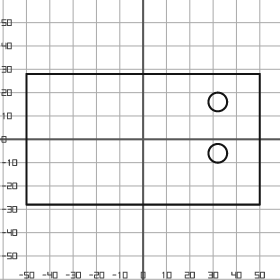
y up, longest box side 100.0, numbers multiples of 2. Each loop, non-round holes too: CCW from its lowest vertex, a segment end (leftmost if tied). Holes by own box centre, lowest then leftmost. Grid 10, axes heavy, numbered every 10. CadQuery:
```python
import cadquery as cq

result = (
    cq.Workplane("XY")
    .moveTo(-50.0, -28.0)
    .lineTo(50.0, -28.0)
    .lineTo(50.0, 28.0)
    .lineTo(-50.0, 28.0)
    .close()
    .moveTo(32.0, -6.0)
    .circle(4.0)
    .moveTo(32.0, 16.0)
    .circle(4.0)
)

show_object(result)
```